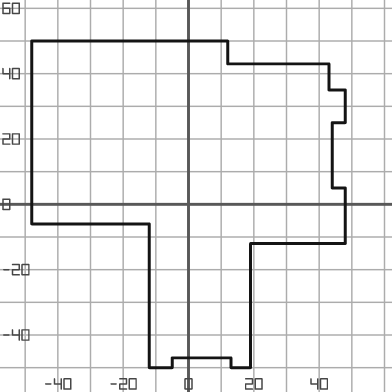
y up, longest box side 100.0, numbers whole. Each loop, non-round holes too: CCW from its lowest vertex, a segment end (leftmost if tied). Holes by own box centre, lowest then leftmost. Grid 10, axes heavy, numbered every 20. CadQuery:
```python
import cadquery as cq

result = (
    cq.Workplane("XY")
    .moveTo(-12.0, -50.0)
    .lineTo(-5.0, -50.0)
    .lineTo(-5.0, -47.0)
    .lineTo(13.0, -47.0)
    .lineTo(13.0, -50.0)
    .lineTo(19.0, -50.0)
    .lineTo(19.0, -12.0)
    .lineTo(48.0, -12.0)
    .lineTo(48.0, 5.0)
    .lineTo(44.0, 5.0)
    .lineTo(44.0, 25.0)
    .lineTo(48.0, 25.0)
    .lineTo(48.0, 35.0)
    .lineTo(43.0, 35.0)
    .lineTo(43.0, 43.0)
    .lineTo(12.0, 43.0)
    .lineTo(12.0, 50.0)
    .lineTo(-48.0, 50.0)
    .lineTo(-48.0, -6.0)
    .lineTo(-12.0, -6.0)
    .close()
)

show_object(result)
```